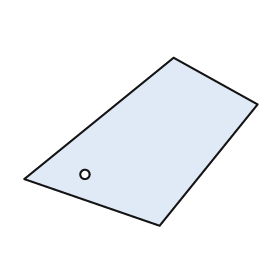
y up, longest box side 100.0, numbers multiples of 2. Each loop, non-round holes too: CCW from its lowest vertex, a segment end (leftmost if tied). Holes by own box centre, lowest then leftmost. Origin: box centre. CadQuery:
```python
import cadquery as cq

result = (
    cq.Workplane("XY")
    .moveTo(8.0, -36.0)
    .lineTo(50.0, 16.0)
    .lineTo(14.0, 36.0)
    .lineTo(-50.0, -16.0)
    .close()
    .moveTo(-24.0, -14.0)
    .circle(2.0)
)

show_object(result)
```